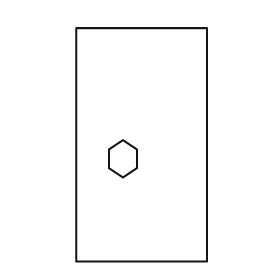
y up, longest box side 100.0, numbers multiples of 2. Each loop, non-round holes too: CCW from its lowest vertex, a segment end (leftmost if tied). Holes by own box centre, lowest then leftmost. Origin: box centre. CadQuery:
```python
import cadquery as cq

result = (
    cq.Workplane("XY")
    .moveTo(-28.0, -50.0)
    .lineTo(28.0, -50.0)
    .lineTo(28.0, 50.0)
    .lineTo(-28.0, 50.0)
    .close()
    .moveTo(-8.0, -14.0)
    .lineTo(-2.0, -10.0)
    .lineTo(-2.0, -2.0)
    .lineTo(-8.0, 2.0)
    .lineTo(-14.0, -2.0)
    .lineTo(-14.0, -10.0)
    .close()
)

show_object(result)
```